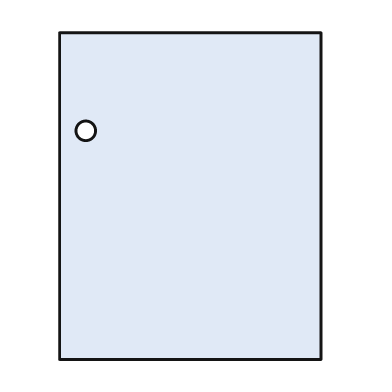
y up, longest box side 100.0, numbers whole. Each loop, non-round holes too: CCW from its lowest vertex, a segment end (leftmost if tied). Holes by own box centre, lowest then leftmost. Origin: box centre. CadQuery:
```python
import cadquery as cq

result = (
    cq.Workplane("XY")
    .moveTo(-40.0, -50.0)
    .lineTo(40.0, -50.0)
    .lineTo(40.0, 50.0)
    .lineTo(-40.0, 50.0)
    .close()
    .moveTo(-32.0, 20.0)
    .circle(3.0)
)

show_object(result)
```